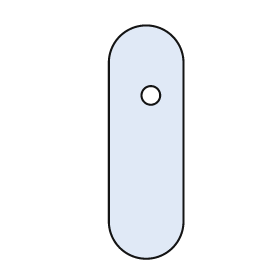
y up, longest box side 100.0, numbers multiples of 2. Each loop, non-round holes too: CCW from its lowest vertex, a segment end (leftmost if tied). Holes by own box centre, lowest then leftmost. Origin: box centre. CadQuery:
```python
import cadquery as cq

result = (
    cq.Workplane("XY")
    .moveTo(-16.0, -34.0)
    .threePointArc((0.0, -50.0), (16.0, -34.0))
    .lineTo(16.0, 34.0)
    .threePointArc((0.0, 50.0), (-16.0, 34.0))
    .close()
    .moveTo(2.0, 20.0)
    .circle(4.0)
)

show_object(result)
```